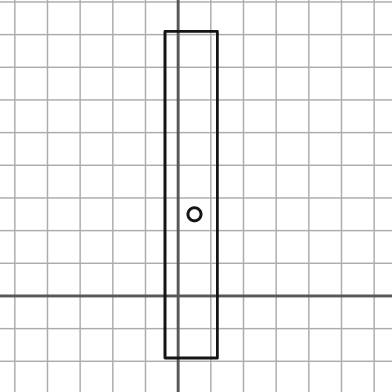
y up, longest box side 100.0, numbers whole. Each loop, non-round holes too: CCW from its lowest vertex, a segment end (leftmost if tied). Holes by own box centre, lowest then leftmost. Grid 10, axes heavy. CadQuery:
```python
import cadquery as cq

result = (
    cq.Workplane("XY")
    .moveTo(-4.0, -19.0)
    .lineTo(12.0, -19.0)
    .lineTo(12.0, 81.0)
    .lineTo(-4.0, 81.0)
    .close()
    .moveTo(5.0, 25.0)
    .circle(2.0)
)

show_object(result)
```